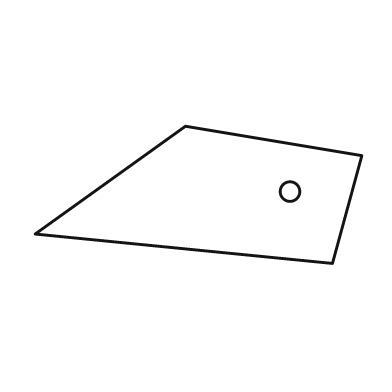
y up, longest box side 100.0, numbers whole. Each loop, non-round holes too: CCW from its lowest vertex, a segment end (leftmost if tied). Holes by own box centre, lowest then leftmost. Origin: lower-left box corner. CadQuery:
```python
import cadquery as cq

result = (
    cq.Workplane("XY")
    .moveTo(91.0, 0.0)
    .lineTo(100.0, 33.0)
    .lineTo(46.0, 42.0)
    .lineTo(0.0, 9.0)
    .close()
    .moveTo(78.0, 22.0)
    .circle(3.0)
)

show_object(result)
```